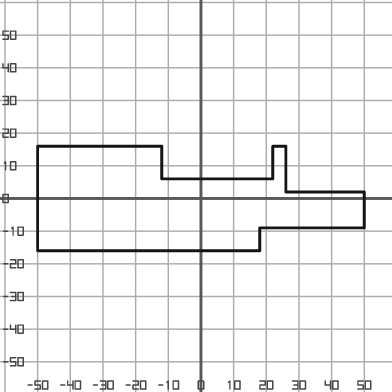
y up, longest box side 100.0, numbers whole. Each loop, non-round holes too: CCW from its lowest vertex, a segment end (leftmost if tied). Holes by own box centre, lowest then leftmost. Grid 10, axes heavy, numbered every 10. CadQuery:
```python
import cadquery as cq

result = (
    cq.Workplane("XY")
    .moveTo(-50.0, -16.0)
    .lineTo(18.0, -16.0)
    .lineTo(18.0, -9.0)
    .lineTo(50.0, -9.0)
    .lineTo(50.0, 2.0)
    .lineTo(26.0, 2.0)
    .lineTo(26.0, 16.0)
    .lineTo(22.0, 16.0)
    .lineTo(22.0, 6.0)
    .lineTo(-12.0, 6.0)
    .lineTo(-12.0, 16.0)
    .lineTo(-50.0, 16.0)
    .close()
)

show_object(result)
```